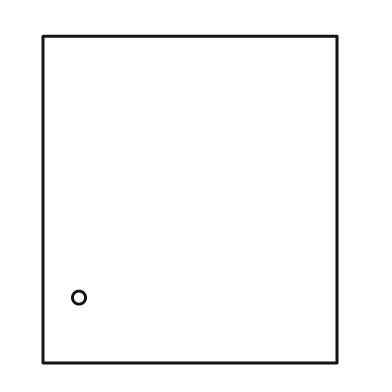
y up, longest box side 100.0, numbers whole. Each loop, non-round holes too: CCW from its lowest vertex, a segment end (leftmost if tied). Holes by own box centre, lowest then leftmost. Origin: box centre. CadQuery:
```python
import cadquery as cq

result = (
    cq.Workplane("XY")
    .moveTo(-45.0, -50.0)
    .lineTo(45.0, -50.0)
    .lineTo(45.0, 50.0)
    .lineTo(-45.0, 50.0)
    .close()
    .moveTo(-34.0, -30.0)
    .circle(2.0)
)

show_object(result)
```